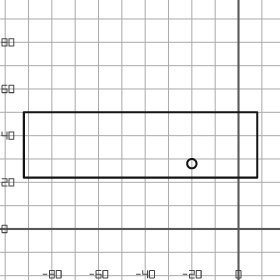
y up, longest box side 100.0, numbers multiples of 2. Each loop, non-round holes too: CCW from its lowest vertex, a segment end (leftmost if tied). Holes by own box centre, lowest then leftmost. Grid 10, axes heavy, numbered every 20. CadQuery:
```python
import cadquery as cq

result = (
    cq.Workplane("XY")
    .moveTo(-92.0, 22.0)
    .lineTo(8.0, 22.0)
    .lineTo(8.0, 50.0)
    .lineTo(-92.0, 50.0)
    .close()
    .moveTo(-20.0, 28.0)
    .circle(2.0)
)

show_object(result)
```